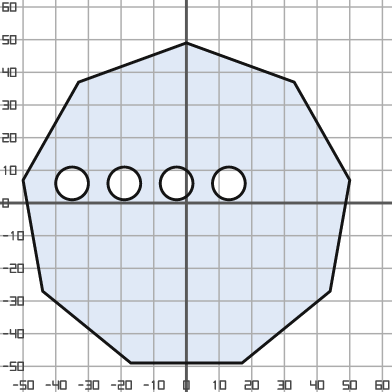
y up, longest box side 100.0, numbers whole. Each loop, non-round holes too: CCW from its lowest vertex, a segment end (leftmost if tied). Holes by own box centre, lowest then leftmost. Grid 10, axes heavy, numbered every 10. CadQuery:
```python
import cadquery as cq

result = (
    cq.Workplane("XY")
    .moveTo(-17.0, -49.0)
    .lineTo(17.0, -49.0)
    .lineTo(44.0, -27.0)
    .lineTo(50.0, 7.0)
    .lineTo(33.0, 37.0)
    .lineTo(0.0, 49.0)
    .lineTo(-33.0, 37.0)
    .lineTo(-50.0, 7.0)
    .lineTo(-44.0, -27.0)
    .close()
    .moveTo(-35.0, 6.0)
    .circle(5.0)
    .moveTo(-19.0, 6.0)
    .circle(5.0)
    .moveTo(-3.0, 6.0)
    .circle(5.0)
    .moveTo(13.0, 6.0)
    .circle(5.0)
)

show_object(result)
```